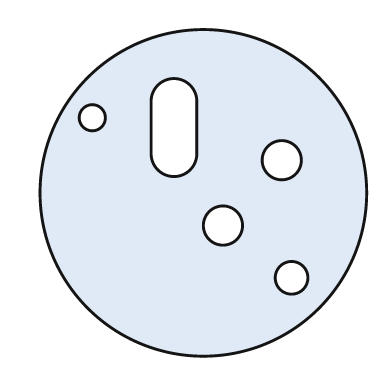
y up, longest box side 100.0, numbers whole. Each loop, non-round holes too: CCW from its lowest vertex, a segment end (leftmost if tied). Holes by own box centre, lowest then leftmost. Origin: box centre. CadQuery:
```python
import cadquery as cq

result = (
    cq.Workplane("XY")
    .moveTo(0.0, 0.0)
    .circle(50.0)
    .moveTo(27.0, -26.0)
    .circle(5.0)
    .moveTo(6.0, -10.0)
    .circle(6.0)
    .moveTo(24.0, 10.0)
    .circle(6.0)
    .moveTo(-16.0, 12.0)
    .threePointArc((-9.0, 5.0), (-2.0, 12.0))
    .lineTo(-2.0, 28.0)
    .threePointArc((-9.0, 35.0), (-16.0, 28.0))
    .close()
    .moveTo(-34.0, 23.0)
    .circle(4.0)
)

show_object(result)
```